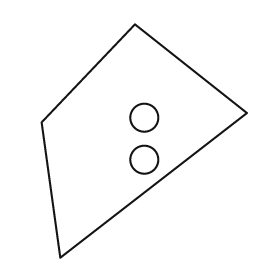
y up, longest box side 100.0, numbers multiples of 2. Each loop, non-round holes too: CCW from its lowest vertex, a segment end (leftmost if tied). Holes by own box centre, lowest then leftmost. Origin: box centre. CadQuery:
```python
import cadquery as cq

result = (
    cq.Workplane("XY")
    .moveTo(-36.0, -50.0)
    .lineTo(44.0, 12.0)
    .lineTo(-4.0, 50.0)
    .lineTo(-44.0, 8.0)
    .close()
    .moveTo(0.0, -8.0)
    .circle(6.0)
    .moveTo(0.0, 10.0)
    .circle(6.0)
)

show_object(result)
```